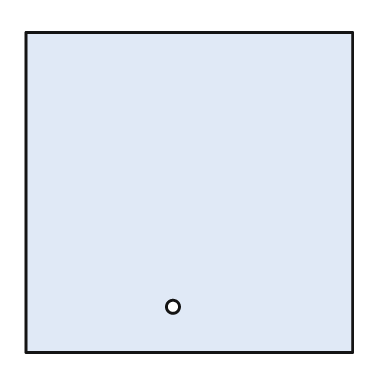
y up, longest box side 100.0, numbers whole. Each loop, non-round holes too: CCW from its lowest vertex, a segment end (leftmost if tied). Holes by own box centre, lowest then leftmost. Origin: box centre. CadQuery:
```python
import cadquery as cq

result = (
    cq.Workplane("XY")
    .moveTo(-50.0, -49.0)
    .lineTo(50.0, -49.0)
    .lineTo(50.0, 49.0)
    .lineTo(-50.0, 49.0)
    .close()
    .moveTo(-5.0, -35.0)
    .circle(2.0)
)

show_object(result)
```